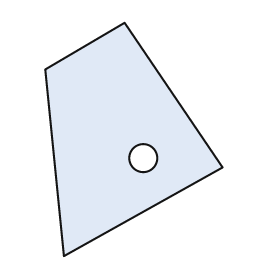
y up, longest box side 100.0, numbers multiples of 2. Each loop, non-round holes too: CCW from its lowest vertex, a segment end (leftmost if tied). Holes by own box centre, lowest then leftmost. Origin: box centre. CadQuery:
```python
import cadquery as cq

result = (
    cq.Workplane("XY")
    .moveTo(-30.0, -50.0)
    .lineTo(38.0, -12.0)
    .lineTo(-4.0, 50.0)
    .lineTo(-38.0, 30.0)
    .close()
    .moveTo(4.0, -8.0)
    .circle(6.0)
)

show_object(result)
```